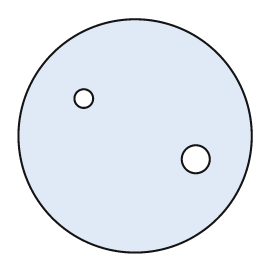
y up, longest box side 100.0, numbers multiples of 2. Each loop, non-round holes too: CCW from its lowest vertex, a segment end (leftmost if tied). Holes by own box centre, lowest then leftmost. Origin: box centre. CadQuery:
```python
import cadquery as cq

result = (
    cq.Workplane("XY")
    .moveTo(0.0, 0.0)
    .circle(50.0)
    .moveTo(26.0, -10.0)
    .circle(6.0)
    .moveTo(-22.0, 16.0)
    .circle(4.0)
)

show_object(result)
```